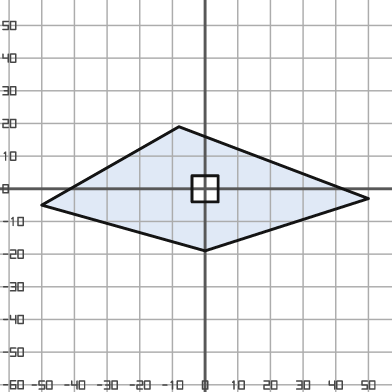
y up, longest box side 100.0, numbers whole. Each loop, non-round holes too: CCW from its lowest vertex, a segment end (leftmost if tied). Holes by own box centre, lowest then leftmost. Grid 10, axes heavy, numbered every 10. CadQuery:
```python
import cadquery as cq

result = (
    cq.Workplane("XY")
    .moveTo(0.0, -19.0)
    .lineTo(50.0, -3.0)
    .lineTo(-8.0, 19.0)
    .lineTo(-50.0, -5.0)
    .close()
    .moveTo(-4.0, -4.0)
    .lineTo(4.0, -4.0)
    .lineTo(4.0, 4.0)
    .lineTo(-4.0, 4.0)
    .close()
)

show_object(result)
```